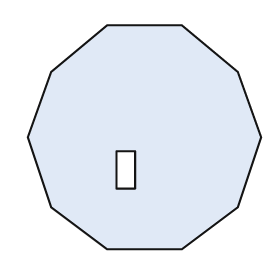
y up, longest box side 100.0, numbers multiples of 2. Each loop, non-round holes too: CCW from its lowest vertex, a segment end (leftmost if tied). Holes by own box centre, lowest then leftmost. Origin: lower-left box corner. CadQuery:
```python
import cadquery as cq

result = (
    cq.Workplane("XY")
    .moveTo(34.0, 0.0)
    .lineTo(66.0, 0.0)
    .lineTo(90.0, 18.0)
    .lineTo(100.0, 48.0)
    .lineTo(90.0, 76.0)
    .lineTo(66.0, 96.0)
    .lineTo(34.0, 96.0)
    .lineTo(10.0, 76.0)
    .lineTo(0.0, 48.0)
    .lineTo(10.0, 18.0)
    .close()
    .moveTo(38.0, 26.0)
    .lineTo(46.0, 26.0)
    .lineTo(46.0, 42.0)
    .lineTo(38.0, 42.0)
    .close()
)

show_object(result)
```